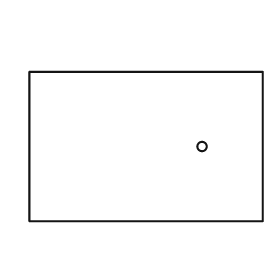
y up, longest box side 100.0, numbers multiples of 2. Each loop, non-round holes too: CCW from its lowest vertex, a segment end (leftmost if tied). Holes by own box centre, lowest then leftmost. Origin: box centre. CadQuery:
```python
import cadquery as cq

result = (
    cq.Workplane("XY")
    .moveTo(-50.0, -32.0)
    .lineTo(50.0, -32.0)
    .lineTo(50.0, 32.0)
    .lineTo(-50.0, 32.0)
    .close()
    .moveTo(24.0, 0.0)
    .circle(2.0)
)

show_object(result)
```